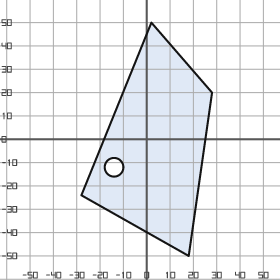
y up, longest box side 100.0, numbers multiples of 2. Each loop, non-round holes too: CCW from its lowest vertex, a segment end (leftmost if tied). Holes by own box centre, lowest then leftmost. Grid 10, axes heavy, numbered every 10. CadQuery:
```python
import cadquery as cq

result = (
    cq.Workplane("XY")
    .moveTo(18.0, -50.0)
    .lineTo(28.0, 20.0)
    .lineTo(2.0, 50.0)
    .lineTo(-28.0, -24.0)
    .close()
    .moveTo(-14.0, -12.0)
    .circle(4.0)
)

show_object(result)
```